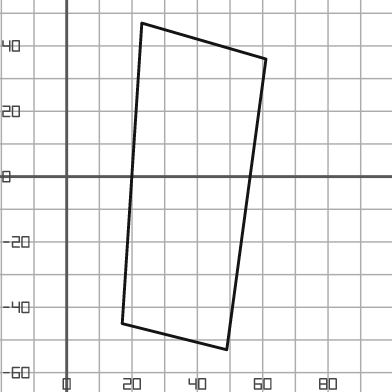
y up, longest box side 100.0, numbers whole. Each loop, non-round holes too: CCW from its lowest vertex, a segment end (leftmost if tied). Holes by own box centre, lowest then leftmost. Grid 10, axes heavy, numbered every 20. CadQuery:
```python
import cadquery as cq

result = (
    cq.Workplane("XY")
    .moveTo(49.0, -53.0)
    .lineTo(61.0, 36.0)
    .lineTo(23.0, 47.0)
    .lineTo(17.0, -45.0)
    .close()
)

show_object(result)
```